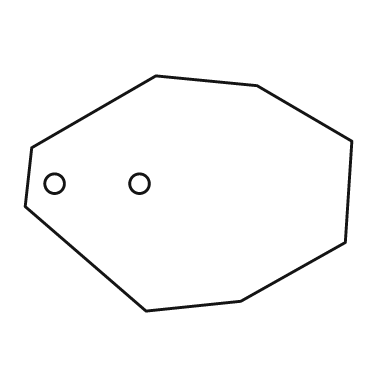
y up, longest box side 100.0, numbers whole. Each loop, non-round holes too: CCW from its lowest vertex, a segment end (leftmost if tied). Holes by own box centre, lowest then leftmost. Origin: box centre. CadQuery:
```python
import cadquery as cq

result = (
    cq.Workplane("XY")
    .moveTo(-13.0, -36.0)
    .lineTo(16.0, -33.0)
    .lineTo(48.0, -15.0)
    .lineTo(50.0, 16.0)
    .lineTo(21.0, 33.0)
    .lineTo(-10.0, 36.0)
    .lineTo(-48.0, 14.0)
    .lineTo(-50.0, -4.0)
    .close()
    .moveTo(-41.0, 3.0)
    .circle(3.0)
    .moveTo(-15.0, 3.0)
    .circle(3.0)
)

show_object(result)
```